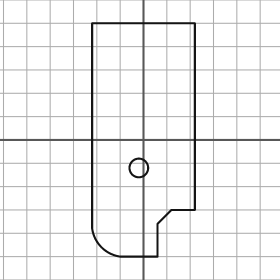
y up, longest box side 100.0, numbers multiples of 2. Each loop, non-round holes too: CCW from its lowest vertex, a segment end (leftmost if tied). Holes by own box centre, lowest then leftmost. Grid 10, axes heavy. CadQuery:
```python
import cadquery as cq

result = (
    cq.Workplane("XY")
    .moveTo(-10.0, -50.0)
    .lineTo(6.0, -50.0)
    .lineTo(6.0, -36.0)
    .lineTo(12.0, -30.0)
    .lineTo(22.0, -30.0)
    .lineTo(22.0, 50.0)
    .lineTo(-22.0, 50.0)
    .lineTo(-22.0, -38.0)
    .threePointArc((-18.0, -46.0), (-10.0, -50.0))
    .close()
    .moveTo(-2.0, -12.0)
    .circle(4.0)
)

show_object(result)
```